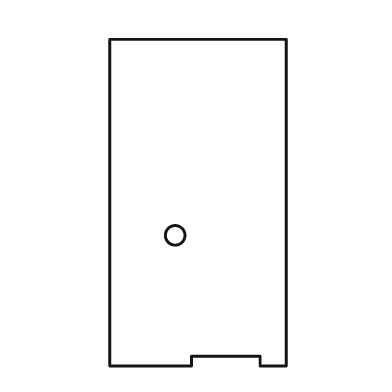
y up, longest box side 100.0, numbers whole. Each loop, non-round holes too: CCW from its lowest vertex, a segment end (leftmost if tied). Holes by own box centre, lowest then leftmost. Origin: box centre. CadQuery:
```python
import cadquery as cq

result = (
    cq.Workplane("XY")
    .moveTo(-27.0, -50.0)
    .lineTo(-2.0, -50.0)
    .lineTo(-2.0, -47.0)
    .lineTo(19.0, -47.0)
    .lineTo(19.0, -50.0)
    .lineTo(27.0, -50.0)
    .lineTo(27.0, 50.0)
    .lineTo(-27.0, 50.0)
    .close()
    .moveTo(-7.0, -10.0)
    .circle(3.0)
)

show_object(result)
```